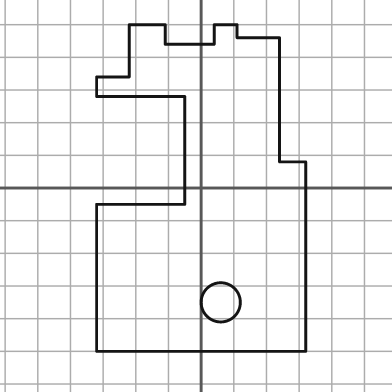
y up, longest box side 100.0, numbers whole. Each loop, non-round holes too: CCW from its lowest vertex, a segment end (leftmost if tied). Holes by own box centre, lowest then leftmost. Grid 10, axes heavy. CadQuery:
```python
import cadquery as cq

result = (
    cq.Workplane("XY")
    .moveTo(-32.0, -50.0)
    .lineTo(32.0, -50.0)
    .lineTo(32.0, 8.0)
    .lineTo(24.0, 8.0)
    .lineTo(24.0, 46.0)
    .lineTo(11.0, 46.0)
    .lineTo(11.0, 50.0)
    .lineTo(4.0, 50.0)
    .lineTo(4.0, 44.0)
    .lineTo(-11.0, 44.0)
    .lineTo(-11.0, 50.0)
    .lineTo(-22.0, 50.0)
    .lineTo(-22.0, 34.0)
    .lineTo(-32.0, 34.0)
    .lineTo(-32.0, 28.0)
    .lineTo(-5.0, 28.0)
    .lineTo(-5.0, -5.0)
    .lineTo(-32.0, -5.0)
    .close()
    .moveTo(6.0, -35.0)
    .circle(6.0)
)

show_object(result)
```